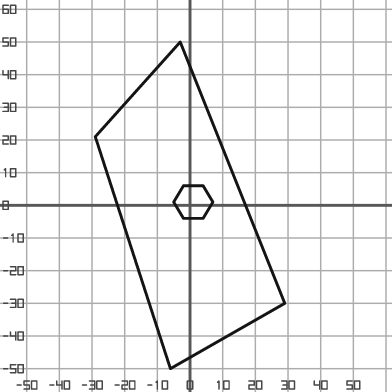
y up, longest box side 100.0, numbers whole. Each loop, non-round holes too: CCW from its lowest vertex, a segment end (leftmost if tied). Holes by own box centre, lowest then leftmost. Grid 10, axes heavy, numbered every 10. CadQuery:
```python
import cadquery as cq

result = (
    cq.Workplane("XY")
    .moveTo(-6.0, -50.0)
    .lineTo(29.0, -30.0)
    .lineTo(-3.0, 50.0)
    .lineTo(-29.0, 21.0)
    .close()
    .moveTo(-2.0, -4.0)
    .lineTo(4.0, -4.0)
    .lineTo(7.0, 1.0)
    .lineTo(4.0, 6.0)
    .lineTo(-2.0, 6.0)
    .lineTo(-5.0, 1.0)
    .close()
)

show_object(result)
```